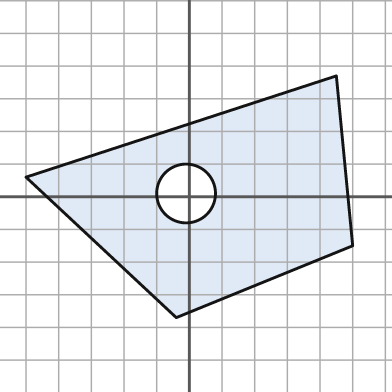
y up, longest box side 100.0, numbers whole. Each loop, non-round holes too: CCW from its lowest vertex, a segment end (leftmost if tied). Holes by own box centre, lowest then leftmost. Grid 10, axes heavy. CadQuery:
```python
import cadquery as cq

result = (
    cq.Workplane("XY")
    .moveTo(-4.0, -37.0)
    .lineTo(50.0, -15.0)
    .lineTo(45.0, 37.0)
    .lineTo(-50.0, 6.0)
    .close()
    .moveTo(-1.0, 1.0)
    .circle(9.0)
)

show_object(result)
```